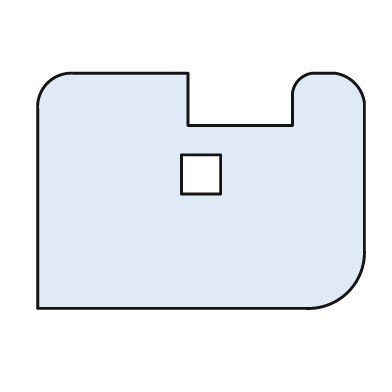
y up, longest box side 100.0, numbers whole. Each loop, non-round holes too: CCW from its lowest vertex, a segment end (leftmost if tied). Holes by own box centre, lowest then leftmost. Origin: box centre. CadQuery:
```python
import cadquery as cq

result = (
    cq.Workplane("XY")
    .moveTo(-50.0, -36.0)
    .lineTo(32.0, -36.0)
    .threePointArc((45.0, -31.0), (50.0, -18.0))
    .lineTo(50.0, 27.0)
    .threePointArc((47.0, 33.0), (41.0, 36.0))
    .lineTo(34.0, 36.0)
    .threePointArc((30.0, 34.0), (28.0, 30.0))
    .lineTo(28.0, 20.0)
    .lineTo(-4.0, 20.0)
    .lineTo(-4.0, 36.0)
    .lineTo(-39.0, 36.0)
    .threePointArc((-47.0, 33.0), (-50.0, 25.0))
    .close()
    .moveTo(-6.0, -1.0)
    .lineTo(6.0, -1.0)
    .lineTo(6.0, 11.0)
    .lineTo(-6.0, 11.0)
    .close()
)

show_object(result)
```